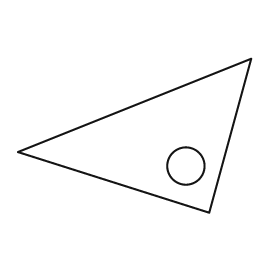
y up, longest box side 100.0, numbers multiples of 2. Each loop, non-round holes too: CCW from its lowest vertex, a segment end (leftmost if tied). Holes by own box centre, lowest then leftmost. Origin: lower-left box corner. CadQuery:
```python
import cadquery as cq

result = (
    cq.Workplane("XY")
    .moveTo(82.0, 0.0)
    .lineTo(100.0, 66.0)
    .lineTo(0.0, 26.0)
    .close()
    .moveTo(72.0, 20.0)
    .circle(8.0)
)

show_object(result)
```